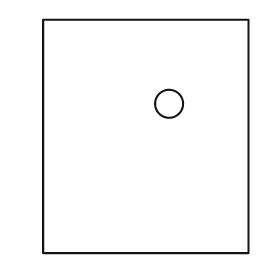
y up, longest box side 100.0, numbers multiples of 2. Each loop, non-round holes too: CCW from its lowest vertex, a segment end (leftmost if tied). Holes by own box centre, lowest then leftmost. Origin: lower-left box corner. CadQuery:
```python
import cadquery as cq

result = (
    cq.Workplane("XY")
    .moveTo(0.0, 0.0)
    .lineTo(88.0, 0.0)
    .lineTo(88.0, 100.0)
    .lineTo(0.0, 100.0)
    .close()
    .moveTo(54.0, 64.0)
    .circle(6.0)
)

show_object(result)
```